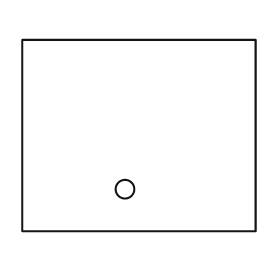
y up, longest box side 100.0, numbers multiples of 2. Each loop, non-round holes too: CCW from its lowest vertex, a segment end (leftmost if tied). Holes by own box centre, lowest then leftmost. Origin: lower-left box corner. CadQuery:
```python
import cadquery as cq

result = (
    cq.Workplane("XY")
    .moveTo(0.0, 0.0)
    .lineTo(100.0, 0.0)
    .lineTo(100.0, 82.0)
    .lineTo(0.0, 82.0)
    .close()
    .moveTo(44.0, 18.0)
    .circle(4.0)
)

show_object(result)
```